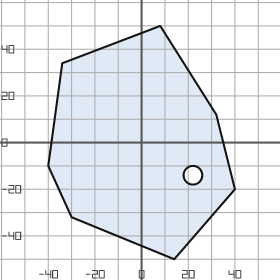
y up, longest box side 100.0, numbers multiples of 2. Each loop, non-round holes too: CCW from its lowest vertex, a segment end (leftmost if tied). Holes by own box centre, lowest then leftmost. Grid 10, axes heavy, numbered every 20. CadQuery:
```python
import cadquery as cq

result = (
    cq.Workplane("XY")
    .moveTo(14.0, -50.0)
    .lineTo(40.0, -20.0)
    .lineTo(32.0, 12.0)
    .lineTo(8.0, 50.0)
    .lineTo(-34.0, 34.0)
    .lineTo(-40.0, -10.0)
    .lineTo(-30.0, -32.0)
    .close()
    .moveTo(22.0, -14.0)
    .circle(4.0)
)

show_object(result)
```